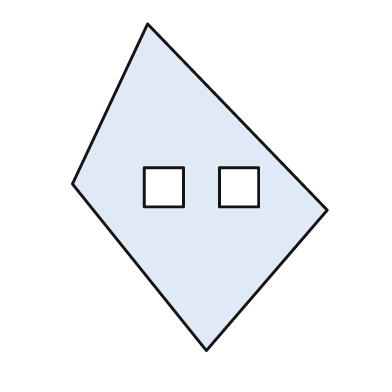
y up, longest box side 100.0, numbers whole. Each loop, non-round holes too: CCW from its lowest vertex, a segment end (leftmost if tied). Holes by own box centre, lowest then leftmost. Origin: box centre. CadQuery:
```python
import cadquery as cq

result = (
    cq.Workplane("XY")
    .moveTo(2.0, -50.0)
    .lineTo(39.0, -7.0)
    .lineTo(-16.0, 50.0)
    .lineTo(-39.0, 1.0)
    .close()
    .moveTo(-17.0, -6.0)
    .lineTo(-5.0, -6.0)
    .lineTo(-5.0, 6.0)
    .lineTo(-17.0, 6.0)
    .close()
    .moveTo(6.0, -6.0)
    .lineTo(18.0, -6.0)
    .lineTo(18.0, 6.0)
    .lineTo(6.0, 6.0)
    .close()
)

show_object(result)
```